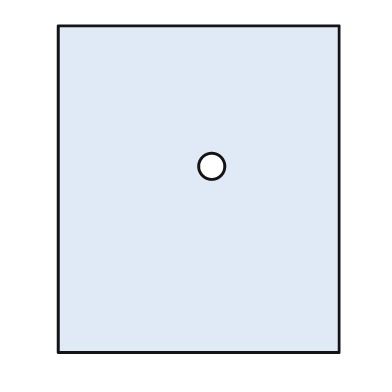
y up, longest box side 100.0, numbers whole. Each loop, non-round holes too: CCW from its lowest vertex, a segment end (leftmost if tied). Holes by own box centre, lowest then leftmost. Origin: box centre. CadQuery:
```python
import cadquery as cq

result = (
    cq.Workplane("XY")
    .moveTo(-43.0, -50.0)
    .lineTo(43.0, -50.0)
    .lineTo(43.0, 50.0)
    .lineTo(-43.0, 50.0)
    .close()
    .moveTo(4.0, 7.0)
    .circle(4.0)
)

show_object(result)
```